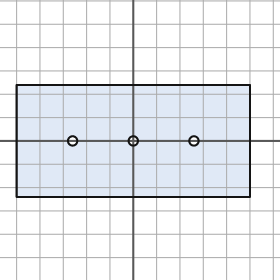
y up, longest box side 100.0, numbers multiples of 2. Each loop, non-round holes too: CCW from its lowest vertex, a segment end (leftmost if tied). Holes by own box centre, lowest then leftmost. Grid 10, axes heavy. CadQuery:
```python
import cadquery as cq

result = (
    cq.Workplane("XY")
    .moveTo(-50.0, -24.0)
    .lineTo(50.0, -24.0)
    .lineTo(50.0, 24.0)
    .lineTo(-50.0, 24.0)
    .close()
    .moveTo(-26.0, 0.0)
    .circle(2.0)
    .moveTo(0.0, 0.0)
    .circle(2.0)
    .moveTo(26.0, 0.0)
    .circle(2.0)
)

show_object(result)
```